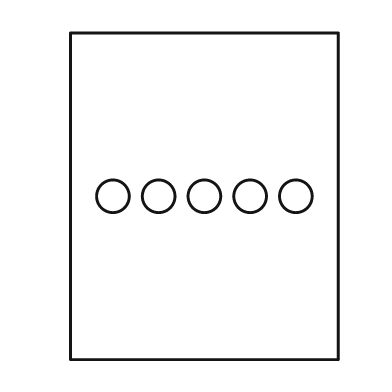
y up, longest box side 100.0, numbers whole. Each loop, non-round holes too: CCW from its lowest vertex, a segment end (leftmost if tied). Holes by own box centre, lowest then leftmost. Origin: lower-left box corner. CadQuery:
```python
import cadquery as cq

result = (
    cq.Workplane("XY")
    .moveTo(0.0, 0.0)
    .lineTo(82.0, 0.0)
    .lineTo(82.0, 100.0)
    .lineTo(0.0, 100.0)
    .close()
    .moveTo(13.0, 50.0)
    .circle(5.0)
    .moveTo(27.0, 50.0)
    .circle(5.0)
    .moveTo(41.0, 50.0)
    .circle(5.0)
    .moveTo(55.0, 50.0)
    .circle(5.0)
    .moveTo(69.0, 50.0)
    .circle(5.0)
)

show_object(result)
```